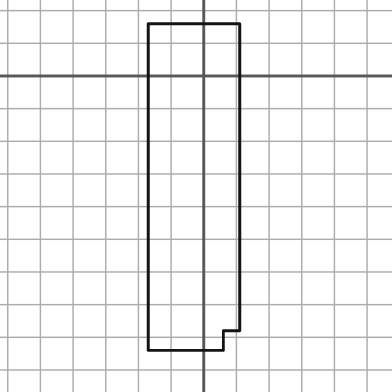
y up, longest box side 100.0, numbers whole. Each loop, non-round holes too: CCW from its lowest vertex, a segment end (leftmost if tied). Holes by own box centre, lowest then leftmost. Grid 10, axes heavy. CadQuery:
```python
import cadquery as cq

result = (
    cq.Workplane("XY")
    .moveTo(-17.0, -84.0)
    .lineTo(6.0, -84.0)
    .lineTo(6.0, -78.0)
    .lineTo(11.0, -78.0)
    .lineTo(11.0, 16.0)
    .lineTo(-17.0, 16.0)
    .close()
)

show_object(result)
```